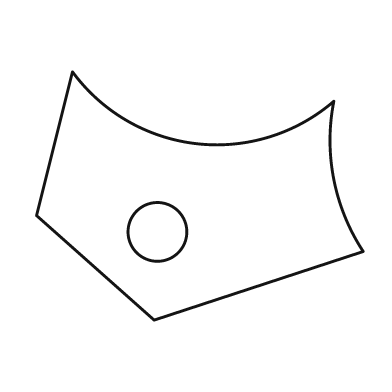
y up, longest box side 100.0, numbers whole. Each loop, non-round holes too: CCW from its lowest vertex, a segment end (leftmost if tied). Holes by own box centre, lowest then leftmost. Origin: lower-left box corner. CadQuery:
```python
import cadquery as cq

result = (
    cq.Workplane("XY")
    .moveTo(36.0, 0.0)
    .lineTo(100.0, 21.0)
    .threePointArc((91.0, 43.0), (91.0, 67.0))
    .threePointArc((49.0, 54.0), (11.0, 76.0))
    .lineTo(0.0, 32.0)
    .close()
    .moveTo(37.0, 27.0)
    .circle(9.0)
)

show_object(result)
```